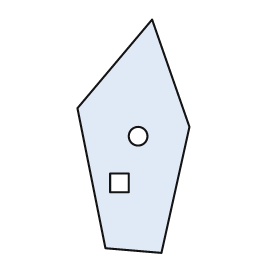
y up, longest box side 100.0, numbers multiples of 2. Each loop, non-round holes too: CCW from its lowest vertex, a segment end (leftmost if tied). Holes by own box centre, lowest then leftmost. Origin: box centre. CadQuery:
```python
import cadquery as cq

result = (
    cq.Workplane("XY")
    .moveTo(12.0, -50.0)
    .lineTo(24.0, 4.0)
    .lineTo(8.0, 50.0)
    .lineTo(-24.0, 12.0)
    .lineTo(-12.0, -48.0)
    .close()
    .moveTo(-10.0, -24.0)
    .lineTo(-2.0, -24.0)
    .lineTo(-2.0, -16.0)
    .lineTo(-10.0, -16.0)
    .close()
    .moveTo(2.0, 0.0)
    .circle(4.0)
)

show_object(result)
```